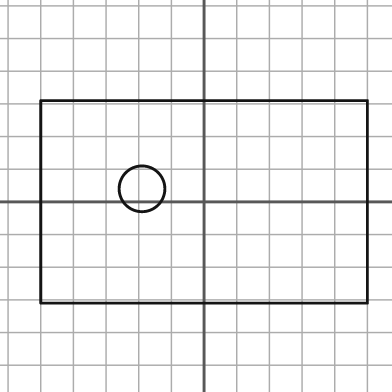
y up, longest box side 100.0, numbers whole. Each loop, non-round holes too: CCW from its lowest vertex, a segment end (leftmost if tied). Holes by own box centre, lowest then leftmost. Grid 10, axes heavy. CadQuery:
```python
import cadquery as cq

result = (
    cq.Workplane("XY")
    .moveTo(-50.0, -31.0)
    .lineTo(50.0, -31.0)
    .lineTo(50.0, 31.0)
    .lineTo(-50.0, 31.0)
    .close()
    .moveTo(-19.0, 4.0)
    .circle(7.0)
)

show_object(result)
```